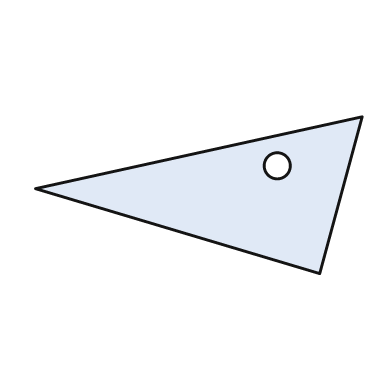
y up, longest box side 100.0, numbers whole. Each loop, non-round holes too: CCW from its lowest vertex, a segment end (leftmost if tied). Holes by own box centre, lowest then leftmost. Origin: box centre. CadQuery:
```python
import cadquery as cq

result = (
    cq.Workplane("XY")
    .moveTo(37.0, -24.0)
    .lineTo(50.0, 24.0)
    .lineTo(-50.0, 2.0)
    .close()
    .moveTo(24.0, 9.0)
    .circle(4.0)
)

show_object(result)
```